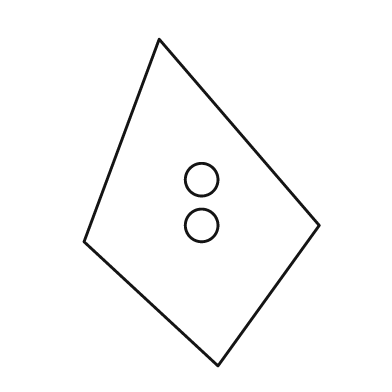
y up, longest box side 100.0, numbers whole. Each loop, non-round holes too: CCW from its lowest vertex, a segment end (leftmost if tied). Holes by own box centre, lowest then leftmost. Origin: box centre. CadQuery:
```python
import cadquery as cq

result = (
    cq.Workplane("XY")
    .moveTo(5.0, -50.0)
    .lineTo(36.0, -7.0)
    .lineTo(-13.0, 50.0)
    .lineTo(-36.0, -12.0)
    .close()
    .moveTo(0.0, -7.0)
    .circle(5.0)
    .moveTo(0.0, 7.0)
    .circle(5.0)
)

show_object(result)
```